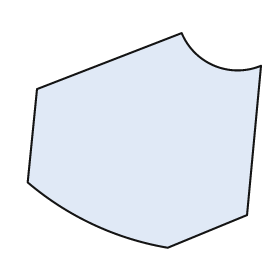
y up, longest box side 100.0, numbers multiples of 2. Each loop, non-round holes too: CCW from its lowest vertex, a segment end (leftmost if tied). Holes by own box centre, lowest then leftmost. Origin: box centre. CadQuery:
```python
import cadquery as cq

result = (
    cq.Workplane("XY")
    .moveTo(10.0, -46.0)
    .lineTo(44.0, -32.0)
    .lineTo(50.0, 32.0)
    .threePointArc((30.0, 32.0), (16.0, 46.0))
    .lineTo(-46.0, 22.0)
    .lineTo(-50.0, -18.0)
    .threePointArc((-22.0, -36.0), (10.0, -46.0))
    .close()
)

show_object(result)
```